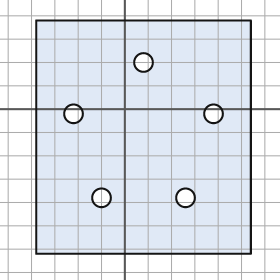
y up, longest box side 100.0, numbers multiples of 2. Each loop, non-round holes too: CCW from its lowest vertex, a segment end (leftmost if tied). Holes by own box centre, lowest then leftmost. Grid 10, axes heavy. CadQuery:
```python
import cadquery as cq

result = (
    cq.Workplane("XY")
    .moveTo(-38.0, -62.0)
    .lineTo(54.0, -62.0)
    .lineTo(54.0, 38.0)
    .lineTo(-38.0, 38.0)
    .close()
    .moveTo(-10.0, -38.0)
    .circle(4.0)
    .moveTo(26.0, -38.0)
    .circle(4.0)
    .moveTo(-22.0, -2.0)
    .circle(4.0)
    .moveTo(38.0, -2.0)
    .circle(4.0)
    .moveTo(8.0, 20.0)
    .circle(4.0)
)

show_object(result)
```